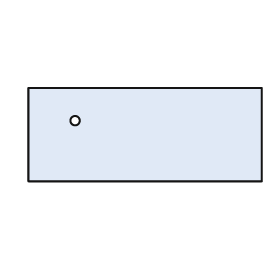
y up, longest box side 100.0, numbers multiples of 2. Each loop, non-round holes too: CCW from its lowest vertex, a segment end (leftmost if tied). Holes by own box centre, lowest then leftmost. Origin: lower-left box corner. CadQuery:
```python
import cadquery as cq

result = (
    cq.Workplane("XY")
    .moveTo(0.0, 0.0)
    .lineTo(100.0, 0.0)
    .lineTo(100.0, 40.0)
    .lineTo(0.0, 40.0)
    .close()
    .moveTo(20.0, 26.0)
    .circle(2.0)
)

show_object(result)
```